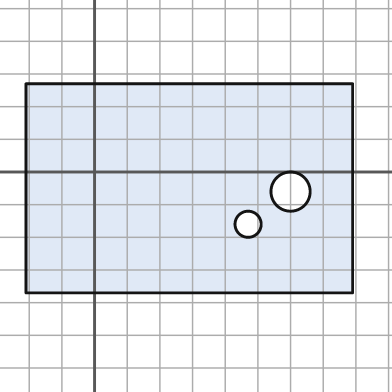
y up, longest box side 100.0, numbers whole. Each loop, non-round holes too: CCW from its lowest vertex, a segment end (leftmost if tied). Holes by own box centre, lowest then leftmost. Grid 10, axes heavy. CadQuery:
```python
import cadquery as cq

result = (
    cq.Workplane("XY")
    .moveTo(-21.0, -37.0)
    .lineTo(79.0, -37.0)
    .lineTo(79.0, 27.0)
    .lineTo(-21.0, 27.0)
    .close()
    .moveTo(47.0, -16.0)
    .circle(4.0)
    .moveTo(60.0, -6.0)
    .circle(6.0)
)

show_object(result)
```